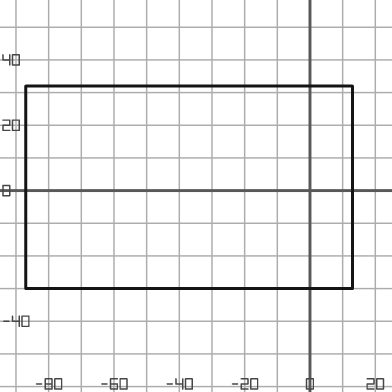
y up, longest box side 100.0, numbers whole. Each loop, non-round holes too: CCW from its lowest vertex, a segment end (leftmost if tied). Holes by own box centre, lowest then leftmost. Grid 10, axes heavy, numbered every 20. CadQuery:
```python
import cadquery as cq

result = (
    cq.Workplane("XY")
    .moveTo(-87.0, -30.0)
    .lineTo(13.0, -30.0)
    .lineTo(13.0, 32.0)
    .lineTo(-87.0, 32.0)
    .close()
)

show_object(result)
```